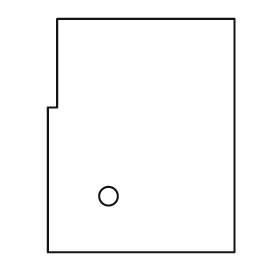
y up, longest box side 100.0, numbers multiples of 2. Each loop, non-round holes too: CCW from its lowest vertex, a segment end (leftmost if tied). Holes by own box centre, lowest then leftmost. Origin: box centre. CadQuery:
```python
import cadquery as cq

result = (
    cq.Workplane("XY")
    .moveTo(-40.0, -50.0)
    .lineTo(40.0, -50.0)
    .lineTo(40.0, 50.0)
    .lineTo(-36.0, 50.0)
    .lineTo(-36.0, 12.0)
    .lineTo(-40.0, 12.0)
    .close()
    .moveTo(-14.0, -26.0)
    .circle(4.0)
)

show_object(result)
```